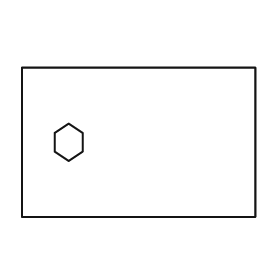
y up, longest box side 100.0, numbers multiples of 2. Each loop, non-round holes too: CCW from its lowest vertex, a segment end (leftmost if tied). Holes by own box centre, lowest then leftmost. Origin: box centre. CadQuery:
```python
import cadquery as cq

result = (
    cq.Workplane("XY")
    .moveTo(-50.0, -32.0)
    .lineTo(50.0, -32.0)
    .lineTo(50.0, 32.0)
    .lineTo(-50.0, 32.0)
    .close()
    .moveTo(-30.0, -8.0)
    .lineTo(-24.0, -4.0)
    .lineTo(-24.0, 4.0)
    .lineTo(-30.0, 8.0)
    .lineTo(-36.0, 4.0)
    .lineTo(-36.0, -4.0)
    .close()
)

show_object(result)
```